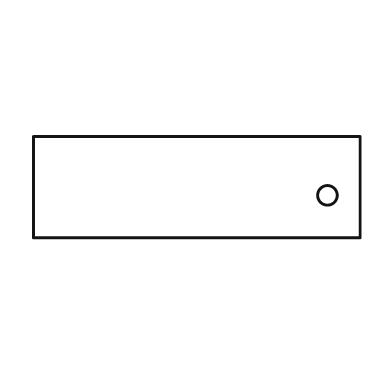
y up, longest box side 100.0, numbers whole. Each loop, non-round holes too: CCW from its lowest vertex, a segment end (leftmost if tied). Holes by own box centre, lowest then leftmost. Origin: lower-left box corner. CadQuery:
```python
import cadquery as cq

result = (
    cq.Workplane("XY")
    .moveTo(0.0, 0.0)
    .lineTo(100.0, 0.0)
    .lineTo(100.0, 31.0)
    .lineTo(0.0, 31.0)
    .close()
    .moveTo(90.0, 13.0)
    .circle(3.0)
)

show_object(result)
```